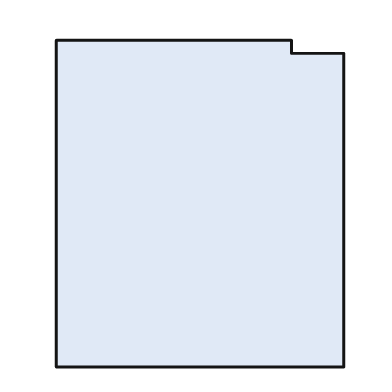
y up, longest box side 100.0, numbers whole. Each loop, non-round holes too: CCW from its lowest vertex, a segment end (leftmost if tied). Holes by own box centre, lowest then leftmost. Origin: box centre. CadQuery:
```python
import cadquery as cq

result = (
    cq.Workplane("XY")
    .moveTo(-44.0, -50.0)
    .lineTo(44.0, -50.0)
    .lineTo(44.0, 46.0)
    .lineTo(28.0, 46.0)
    .lineTo(28.0, 50.0)
    .lineTo(-44.0, 50.0)
    .close()
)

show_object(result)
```